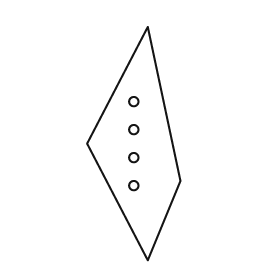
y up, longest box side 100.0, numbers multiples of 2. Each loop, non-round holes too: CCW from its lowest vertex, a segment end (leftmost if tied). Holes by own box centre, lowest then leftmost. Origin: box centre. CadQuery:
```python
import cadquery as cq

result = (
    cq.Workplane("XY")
    .moveTo(6.0, -50.0)
    .lineTo(20.0, -16.0)
    .lineTo(6.0, 50.0)
    .lineTo(-20.0, 0.0)
    .close()
    .moveTo(0.0, -18.0)
    .circle(2.0)
    .moveTo(0.0, -6.0)
    .circle(2.0)
    .moveTo(0.0, 6.0)
    .circle(2.0)
    .moveTo(0.0, 18.0)
    .circle(2.0)
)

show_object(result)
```